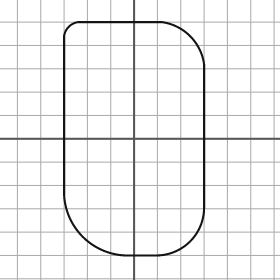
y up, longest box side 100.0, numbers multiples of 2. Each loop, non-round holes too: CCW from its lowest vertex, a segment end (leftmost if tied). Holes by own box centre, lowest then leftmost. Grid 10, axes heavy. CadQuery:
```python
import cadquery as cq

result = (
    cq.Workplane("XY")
    .moveTo(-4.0, -50.0)
    .lineTo(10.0, -50.0)
    .threePointArc((24.0, -44.0), (30.0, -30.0))
    .lineTo(30.0, 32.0)
    .threePointArc((24.0, 44.0), (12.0, 50.0))
    .lineTo(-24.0, 50.0)
    .threePointArc((-28.0, 48.0), (-30.0, 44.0))
    .lineTo(-30.0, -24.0)
    .threePointArc((-22.0, -42.0), (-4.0, -50.0))
    .close()
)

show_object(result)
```